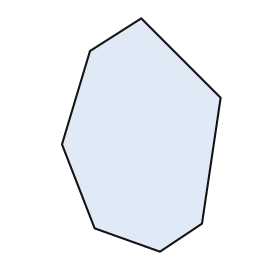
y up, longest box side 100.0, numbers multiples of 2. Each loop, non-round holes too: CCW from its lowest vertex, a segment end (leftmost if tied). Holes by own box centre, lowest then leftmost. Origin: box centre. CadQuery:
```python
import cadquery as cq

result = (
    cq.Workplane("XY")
    .moveTo(8.0, -50.0)
    .lineTo(26.0, -38.0)
    .lineTo(34.0, 16.0)
    .lineTo(0.0, 50.0)
    .lineTo(-22.0, 36.0)
    .lineTo(-34.0, -4.0)
    .lineTo(-20.0, -40.0)
    .close()
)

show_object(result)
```